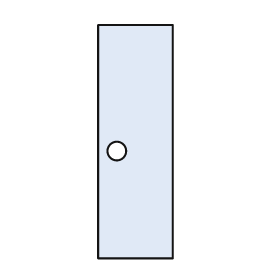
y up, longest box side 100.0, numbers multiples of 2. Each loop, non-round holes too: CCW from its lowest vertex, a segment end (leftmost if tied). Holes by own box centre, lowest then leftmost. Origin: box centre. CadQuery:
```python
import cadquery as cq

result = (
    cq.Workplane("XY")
    .moveTo(-16.0, -50.0)
    .lineTo(16.0, -50.0)
    .lineTo(16.0, 50.0)
    .lineTo(-16.0, 50.0)
    .close()
    .moveTo(-8.0, -4.0)
    .circle(4.0)
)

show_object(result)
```